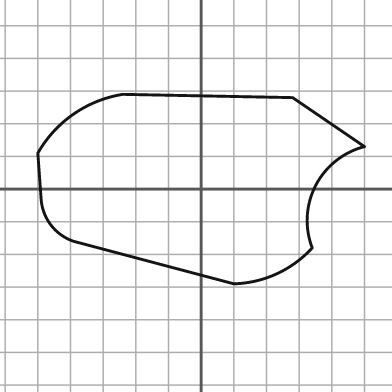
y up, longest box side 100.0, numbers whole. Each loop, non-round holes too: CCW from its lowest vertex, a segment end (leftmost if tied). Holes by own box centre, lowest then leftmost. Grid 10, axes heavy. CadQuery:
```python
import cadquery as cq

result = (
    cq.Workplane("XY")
    .moveTo(10.0, -29.0)
    .threePointArc((23.0, -26.0), (34.0, -18.0))
    .threePointArc((35.0, 1.0), (50.0, 13.0))
    .lineTo(28.0, 28.0)
    .lineTo(-24.0, 29.0)
    .threePointArc((-39.0, 23.0), (-50.0, 11.0))
    .lineTo(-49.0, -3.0)
    .threePointArc((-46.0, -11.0), (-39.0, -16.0))
    .close()
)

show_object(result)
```